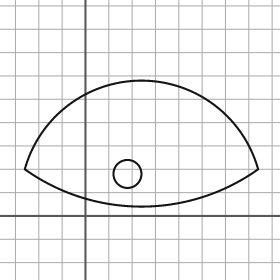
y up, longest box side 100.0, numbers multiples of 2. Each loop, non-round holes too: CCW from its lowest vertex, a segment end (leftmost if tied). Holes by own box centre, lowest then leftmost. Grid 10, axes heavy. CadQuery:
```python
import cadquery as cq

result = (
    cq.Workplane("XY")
    .moveTo(-26.0, 20.0)
    .threePointArc((24.0, 4.0), (74.0, 20.0))
    .threePointArc((24.0, 58.0), (-26.0, 20.0))
    .close()
    .moveTo(18.0, 18.0)
    .circle(6.0)
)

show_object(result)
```